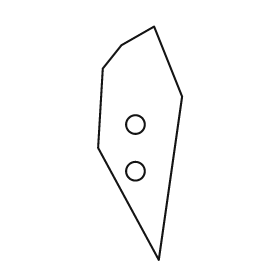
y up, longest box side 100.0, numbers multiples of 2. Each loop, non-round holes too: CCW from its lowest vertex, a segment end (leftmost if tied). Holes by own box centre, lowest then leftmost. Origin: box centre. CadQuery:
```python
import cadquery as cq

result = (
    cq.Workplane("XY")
    .moveTo(8.0, -50.0)
    .lineTo(18.0, 20.0)
    .lineTo(6.0, 50.0)
    .lineTo(-8.0, 42.0)
    .lineTo(-16.0, 32.0)
    .lineTo(-18.0, -2.0)
    .close()
    .moveTo(-2.0, -12.0)
    .circle(4.0)
    .moveTo(-2.0, 8.0)
    .circle(4.0)
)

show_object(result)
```